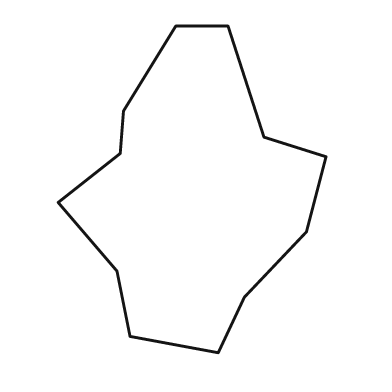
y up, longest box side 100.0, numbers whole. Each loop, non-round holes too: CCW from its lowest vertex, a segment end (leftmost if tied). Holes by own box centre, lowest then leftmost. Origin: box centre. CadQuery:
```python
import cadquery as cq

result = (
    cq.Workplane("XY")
    .moveTo(8.0, -50.0)
    .lineTo(16.0, -33.0)
    .lineTo(35.0, -13.0)
    .lineTo(41.0, 10.0)
    .lineTo(22.0, 16.0)
    .lineTo(11.0, 50.0)
    .lineTo(-5.0, 50.0)
    .lineTo(-21.0, 24.0)
    .lineTo(-22.0, 11.0)
    .lineTo(-41.0, -4.0)
    .lineTo(-23.0, -25.0)
    .lineTo(-19.0, -45.0)
    .close()
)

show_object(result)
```